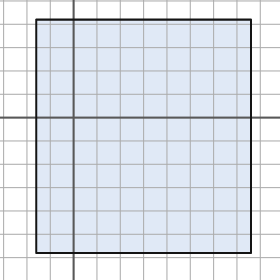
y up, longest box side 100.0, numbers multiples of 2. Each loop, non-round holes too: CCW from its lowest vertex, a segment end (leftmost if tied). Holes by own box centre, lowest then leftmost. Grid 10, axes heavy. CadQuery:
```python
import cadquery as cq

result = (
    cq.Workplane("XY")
    .moveTo(-16.0, -58.0)
    .lineTo(76.0, -58.0)
    .lineTo(76.0, 42.0)
    .lineTo(-16.0, 42.0)
    .close()
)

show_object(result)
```